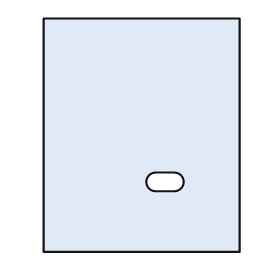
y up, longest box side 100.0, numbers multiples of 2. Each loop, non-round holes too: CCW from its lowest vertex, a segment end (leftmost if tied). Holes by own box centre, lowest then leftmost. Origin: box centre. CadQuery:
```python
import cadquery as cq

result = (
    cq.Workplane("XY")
    .moveTo(-42.0, -50.0)
    .lineTo(42.0, -50.0)
    .lineTo(42.0, 50.0)
    .lineTo(-42.0, 50.0)
    .close()
    .moveTo(6.0, -24.0)
    .lineTo(14.0, -24.0)
    .threePointArc((18.0, -20.0), (14.0, -16.0))
    .lineTo(6.0, -16.0)
    .threePointArc((2.0, -20.0), (6.0, -24.0))
    .close()
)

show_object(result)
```